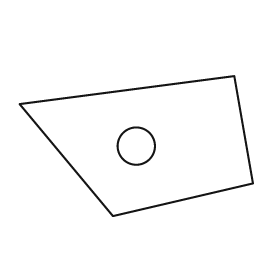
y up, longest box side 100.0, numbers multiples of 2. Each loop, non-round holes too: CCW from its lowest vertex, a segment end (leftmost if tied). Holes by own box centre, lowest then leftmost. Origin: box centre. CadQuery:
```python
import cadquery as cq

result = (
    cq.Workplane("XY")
    .moveTo(-10.0, -30.0)
    .lineTo(50.0, -16.0)
    .lineTo(42.0, 30.0)
    .lineTo(-50.0, 18.0)
    .close()
    .moveTo(0.0, 0.0)
    .circle(8.0)
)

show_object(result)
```